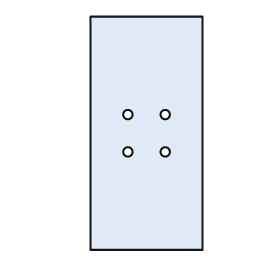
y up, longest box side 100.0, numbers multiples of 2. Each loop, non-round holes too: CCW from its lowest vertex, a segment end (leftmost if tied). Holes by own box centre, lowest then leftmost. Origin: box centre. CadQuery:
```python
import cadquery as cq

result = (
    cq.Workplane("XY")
    .moveTo(-24.0, -50.0)
    .lineTo(24.0, -50.0)
    .lineTo(24.0, 50.0)
    .lineTo(-24.0, 50.0)
    .close()
    .moveTo(-8.0, -8.0)
    .circle(2.0)
    .moveTo(8.0, -8.0)
    .circle(2.0)
    .moveTo(-8.0, 8.0)
    .circle(2.0)
    .moveTo(8.0, 8.0)
    .circle(2.0)
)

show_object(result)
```